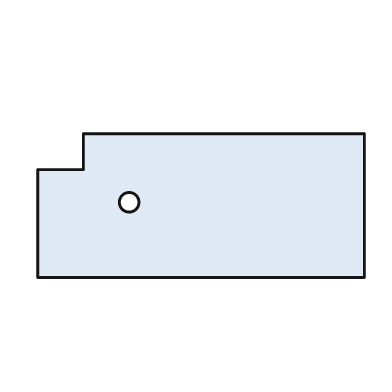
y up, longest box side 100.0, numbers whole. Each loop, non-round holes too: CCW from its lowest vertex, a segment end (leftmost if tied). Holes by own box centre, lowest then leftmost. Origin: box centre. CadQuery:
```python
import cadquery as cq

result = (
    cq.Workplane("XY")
    .moveTo(-50.0, -22.0)
    .lineTo(50.0, -22.0)
    .lineTo(50.0, 22.0)
    .lineTo(-36.0, 22.0)
    .lineTo(-36.0, 11.0)
    .lineTo(-50.0, 11.0)
    .close()
    .moveTo(-22.0, 1.0)
    .circle(3.0)
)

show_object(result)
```